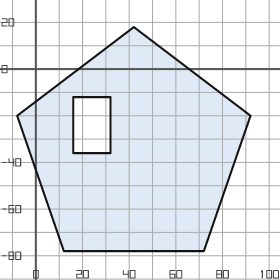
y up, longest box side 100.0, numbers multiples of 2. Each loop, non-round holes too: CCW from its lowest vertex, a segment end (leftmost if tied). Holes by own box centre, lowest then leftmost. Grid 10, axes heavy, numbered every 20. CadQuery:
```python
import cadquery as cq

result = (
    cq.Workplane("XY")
    .moveTo(12.0, -78.0)
    .lineTo(72.0, -78.0)
    .lineTo(92.0, -20.0)
    .lineTo(42.0, 18.0)
    .lineTo(-8.0, -20.0)
    .close()
    .moveTo(16.0, -36.0)
    .lineTo(32.0, -36.0)
    .lineTo(32.0, -12.0)
    .lineTo(16.0, -12.0)
    .close()
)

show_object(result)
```